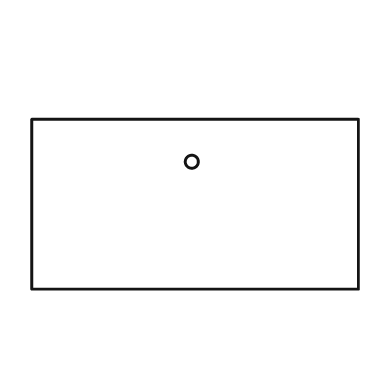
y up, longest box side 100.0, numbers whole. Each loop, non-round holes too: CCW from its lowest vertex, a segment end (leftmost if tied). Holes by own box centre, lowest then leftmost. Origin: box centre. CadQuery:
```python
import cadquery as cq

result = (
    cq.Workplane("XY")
    .moveTo(-50.0, -26.0)
    .lineTo(50.0, -26.0)
    .lineTo(50.0, 26.0)
    .lineTo(-50.0, 26.0)
    .close()
    .moveTo(-1.0, 13.0)
    .circle(2.0)
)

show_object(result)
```